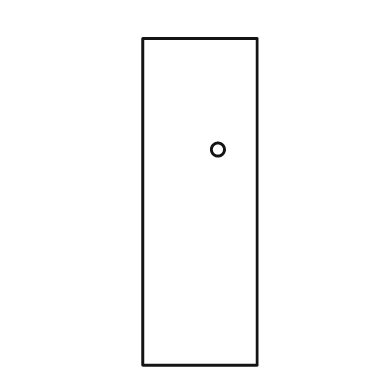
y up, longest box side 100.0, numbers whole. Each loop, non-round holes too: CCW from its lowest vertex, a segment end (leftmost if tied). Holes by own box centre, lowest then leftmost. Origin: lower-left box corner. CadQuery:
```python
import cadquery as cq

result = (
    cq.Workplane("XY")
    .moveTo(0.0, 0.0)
    .lineTo(35.0, 0.0)
    .lineTo(35.0, 100.0)
    .lineTo(0.0, 100.0)
    .close()
    .moveTo(23.0, 66.0)
    .circle(2.0)
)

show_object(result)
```